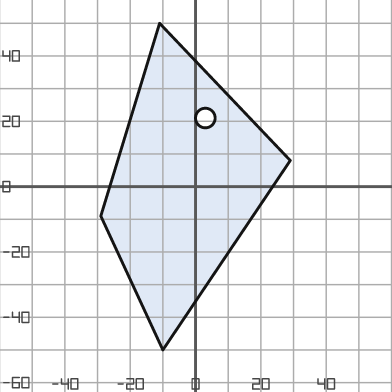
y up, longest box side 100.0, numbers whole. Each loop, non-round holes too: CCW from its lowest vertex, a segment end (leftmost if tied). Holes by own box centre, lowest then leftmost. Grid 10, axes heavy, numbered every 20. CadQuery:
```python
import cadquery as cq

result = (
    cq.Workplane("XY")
    .moveTo(-10.0, -50.0)
    .lineTo(29.0, 8.0)
    .lineTo(-11.0, 50.0)
    .lineTo(-29.0, -9.0)
    .close()
    .moveTo(3.0, 21.0)
    .circle(3.0)
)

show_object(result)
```